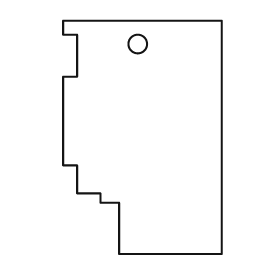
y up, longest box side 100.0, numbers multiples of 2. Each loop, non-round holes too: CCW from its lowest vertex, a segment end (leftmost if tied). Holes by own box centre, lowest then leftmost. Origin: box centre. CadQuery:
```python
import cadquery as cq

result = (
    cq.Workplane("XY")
    .moveTo(-10.0, -50.0)
    .lineTo(34.0, -50.0)
    .lineTo(34.0, 50.0)
    .lineTo(-34.0, 50.0)
    .lineTo(-34.0, 44.0)
    .lineTo(-28.0, 44.0)
    .lineTo(-28.0, 26.0)
    .lineTo(-34.0, 26.0)
    .lineTo(-34.0, -12.0)
    .lineTo(-28.0, -12.0)
    .lineTo(-28.0, -24.0)
    .lineTo(-18.0, -24.0)
    .lineTo(-18.0, -28.0)
    .lineTo(-10.0, -28.0)
    .close()
    .moveTo(-2.0, 40.0)
    .circle(4.0)
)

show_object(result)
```